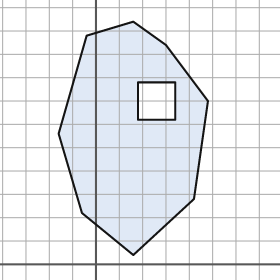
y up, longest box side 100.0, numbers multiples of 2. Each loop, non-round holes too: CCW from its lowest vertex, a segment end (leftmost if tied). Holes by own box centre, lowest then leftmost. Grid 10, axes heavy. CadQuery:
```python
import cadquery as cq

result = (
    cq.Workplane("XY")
    .moveTo(16.0, 4.0)
    .lineTo(42.0, 28.0)
    .lineTo(48.0, 70.0)
    .lineTo(30.0, 94.0)
    .lineTo(16.0, 104.0)
    .lineTo(-4.0, 98.0)
    .lineTo(-16.0, 56.0)
    .lineTo(-6.0, 22.0)
    .close()
    .moveTo(18.0, 62.0)
    .lineTo(34.0, 62.0)
    .lineTo(34.0, 78.0)
    .lineTo(18.0, 78.0)
    .close()
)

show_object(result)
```